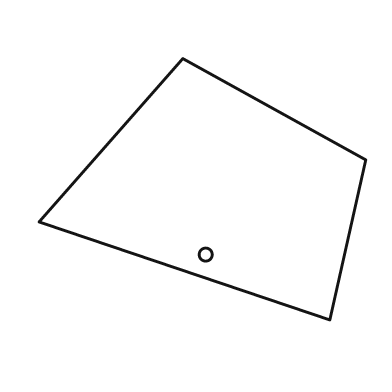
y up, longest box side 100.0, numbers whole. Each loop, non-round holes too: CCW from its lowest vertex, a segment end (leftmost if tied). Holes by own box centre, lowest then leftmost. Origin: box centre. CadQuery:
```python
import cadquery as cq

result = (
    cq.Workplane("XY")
    .moveTo(39.0, -40.0)
    .lineTo(50.0, 9.0)
    .lineTo(-6.0, 40.0)
    .lineTo(-50.0, -10.0)
    .close()
    .moveTo(1.0, -20.0)
    .circle(2.0)
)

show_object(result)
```